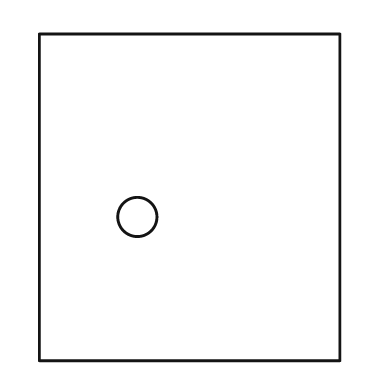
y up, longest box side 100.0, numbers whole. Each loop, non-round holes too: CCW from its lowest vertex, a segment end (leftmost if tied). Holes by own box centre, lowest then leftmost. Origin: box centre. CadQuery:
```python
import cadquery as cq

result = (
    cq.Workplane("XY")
    .moveTo(-46.0, -50.0)
    .lineTo(46.0, -50.0)
    .lineTo(46.0, 50.0)
    .lineTo(-46.0, 50.0)
    .close()
    .moveTo(-16.0, -6.0)
    .circle(6.0)
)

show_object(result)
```